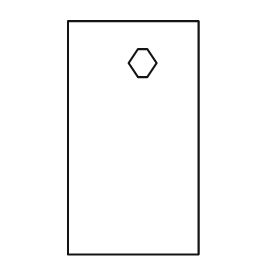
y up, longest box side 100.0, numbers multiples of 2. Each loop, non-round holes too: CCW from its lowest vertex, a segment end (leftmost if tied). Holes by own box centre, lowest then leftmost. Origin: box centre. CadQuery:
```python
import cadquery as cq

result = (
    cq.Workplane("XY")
    .moveTo(-28.0, -50.0)
    .lineTo(28.0, -50.0)
    .lineTo(28.0, 50.0)
    .lineTo(-28.0, 50.0)
    .close()
    .moveTo(2.0, 26.0)
    .lineTo(6.0, 26.0)
    .lineTo(10.0, 32.0)
    .lineTo(6.0, 38.0)
    .lineTo(2.0, 38.0)
    .lineTo(-2.0, 32.0)
    .close()
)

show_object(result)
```